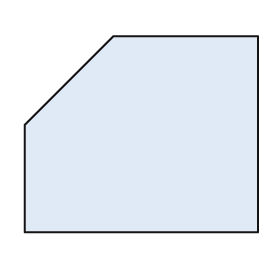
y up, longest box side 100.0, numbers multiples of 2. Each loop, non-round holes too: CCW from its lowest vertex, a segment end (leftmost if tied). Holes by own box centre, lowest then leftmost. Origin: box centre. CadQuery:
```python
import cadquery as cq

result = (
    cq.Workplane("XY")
    .moveTo(-50.0, -42.0)
    .lineTo(50.0, -42.0)
    .lineTo(50.0, 42.0)
    .lineTo(-12.0, 42.0)
    .lineTo(-50.0, 4.0)
    .close()
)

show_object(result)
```